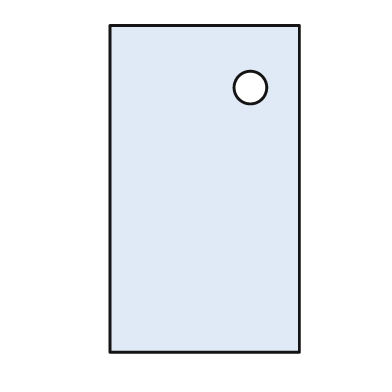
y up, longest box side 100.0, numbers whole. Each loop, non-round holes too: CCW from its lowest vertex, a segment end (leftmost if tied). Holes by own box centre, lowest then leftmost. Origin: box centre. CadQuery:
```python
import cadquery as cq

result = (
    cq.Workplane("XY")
    .moveTo(-29.0, -50.0)
    .lineTo(29.0, -50.0)
    .lineTo(29.0, 50.0)
    .lineTo(-29.0, 50.0)
    .close()
    .moveTo(14.0, 31.0)
    .circle(5.0)
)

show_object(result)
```